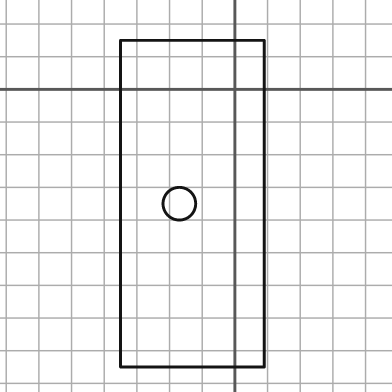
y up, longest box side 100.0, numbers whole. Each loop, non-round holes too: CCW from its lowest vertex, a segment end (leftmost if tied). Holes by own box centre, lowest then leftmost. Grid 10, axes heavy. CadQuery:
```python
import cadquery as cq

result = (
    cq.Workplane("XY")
    .moveTo(-35.0, -85.0)
    .lineTo(9.0, -85.0)
    .lineTo(9.0, 15.0)
    .lineTo(-35.0, 15.0)
    .close()
    .moveTo(-17.0, -35.0)
    .circle(5.0)
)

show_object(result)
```